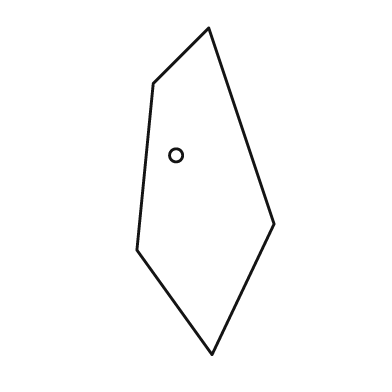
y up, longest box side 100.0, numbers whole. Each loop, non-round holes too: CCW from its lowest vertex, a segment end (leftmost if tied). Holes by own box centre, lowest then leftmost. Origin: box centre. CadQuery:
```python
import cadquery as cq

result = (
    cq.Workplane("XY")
    .moveTo(2.0, -50.0)
    .lineTo(21.0, -10.0)
    .lineTo(1.0, 50.0)
    .lineTo(-16.0, 33.0)
    .lineTo(-21.0, -18.0)
    .close()
    .moveTo(-9.0, 11.0)
    .circle(2.0)
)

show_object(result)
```